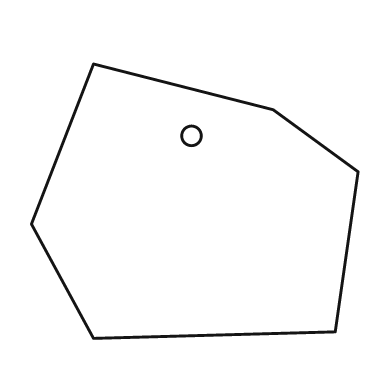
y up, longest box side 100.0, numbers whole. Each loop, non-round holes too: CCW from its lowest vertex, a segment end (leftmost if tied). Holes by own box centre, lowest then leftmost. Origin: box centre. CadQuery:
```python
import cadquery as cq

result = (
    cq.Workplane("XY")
    .moveTo(-31.0, -42.0)
    .lineTo(43.0, -40.0)
    .lineTo(50.0, 9.0)
    .lineTo(24.0, 28.0)
    .lineTo(-31.0, 42.0)
    .lineTo(-50.0, -7.0)
    .close()
    .moveTo(-1.0, 20.0)
    .circle(3.0)
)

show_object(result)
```